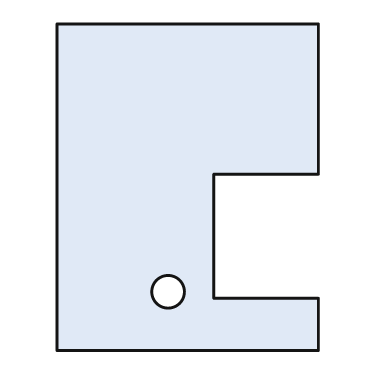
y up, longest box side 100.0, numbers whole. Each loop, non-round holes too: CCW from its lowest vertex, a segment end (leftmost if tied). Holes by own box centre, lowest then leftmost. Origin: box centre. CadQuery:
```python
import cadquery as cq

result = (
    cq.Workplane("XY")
    .moveTo(-40.0, -50.0)
    .lineTo(40.0, -50.0)
    .lineTo(40.0, -34.0)
    .lineTo(8.0, -34.0)
    .lineTo(8.0, 4.0)
    .lineTo(40.0, 4.0)
    .lineTo(40.0, 50.0)
    .lineTo(-40.0, 50.0)
    .close()
    .moveTo(-6.0, -32.0)
    .circle(5.0)
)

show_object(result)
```